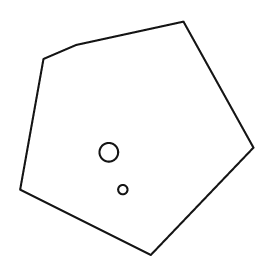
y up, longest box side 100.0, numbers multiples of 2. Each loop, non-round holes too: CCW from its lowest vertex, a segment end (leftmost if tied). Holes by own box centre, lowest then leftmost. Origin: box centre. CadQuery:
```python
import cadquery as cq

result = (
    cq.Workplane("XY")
    .moveTo(6.0, -50.0)
    .lineTo(50.0, -4.0)
    .lineTo(20.0, 50.0)
    .lineTo(-26.0, 40.0)
    .lineTo(-40.0, 34.0)
    .lineTo(-50.0, -22.0)
    .close()
    .moveTo(-6.0, -22.0)
    .circle(2.0)
    .moveTo(-12.0, -6.0)
    .circle(4.0)
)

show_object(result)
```